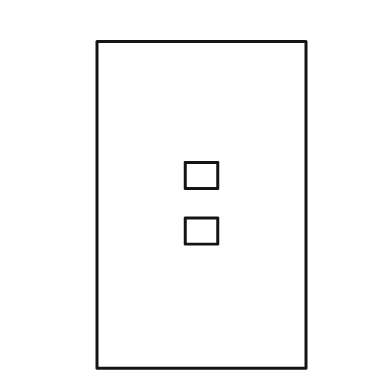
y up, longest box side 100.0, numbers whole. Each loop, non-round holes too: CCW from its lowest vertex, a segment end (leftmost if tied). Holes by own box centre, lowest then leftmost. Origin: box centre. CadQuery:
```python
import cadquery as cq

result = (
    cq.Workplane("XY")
    .moveTo(-32.0, -50.0)
    .lineTo(32.0, -50.0)
    .lineTo(32.0, 50.0)
    .lineTo(-32.0, 50.0)
    .close()
    .moveTo(-5.0, -12.0)
    .lineTo(5.0, -12.0)
    .lineTo(5.0, -4.0)
    .lineTo(-5.0, -4.0)
    .close()
    .moveTo(-5.0, 5.0)
    .lineTo(5.0, 5.0)
    .lineTo(5.0, 13.0)
    .lineTo(-5.0, 13.0)
    .close()
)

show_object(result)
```